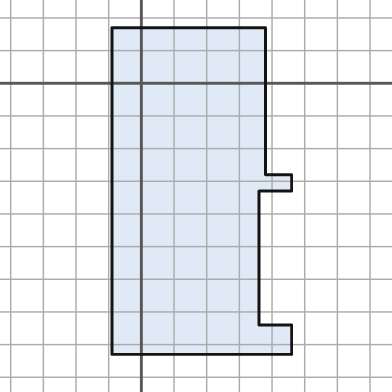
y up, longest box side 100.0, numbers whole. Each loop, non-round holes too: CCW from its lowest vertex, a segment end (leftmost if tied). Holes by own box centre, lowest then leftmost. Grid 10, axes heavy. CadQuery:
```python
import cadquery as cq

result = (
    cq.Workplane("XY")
    .moveTo(-9.0, -83.0)
    .lineTo(46.0, -83.0)
    .lineTo(46.0, -74.0)
    .lineTo(36.0, -74.0)
    .lineTo(36.0, -33.0)
    .lineTo(46.0, -33.0)
    .lineTo(46.0, -28.0)
    .lineTo(38.0, -28.0)
    .lineTo(38.0, 17.0)
    .lineTo(-9.0, 17.0)
    .close()
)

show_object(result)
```